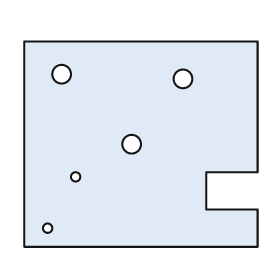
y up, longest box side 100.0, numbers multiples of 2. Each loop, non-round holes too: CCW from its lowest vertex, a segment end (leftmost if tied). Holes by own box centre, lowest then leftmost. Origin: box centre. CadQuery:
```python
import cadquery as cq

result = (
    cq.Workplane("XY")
    .moveTo(-50.0, -44.0)
    .lineTo(50.0, -44.0)
    .lineTo(50.0, -28.0)
    .lineTo(28.0, -28.0)
    .lineTo(28.0, -12.0)
    .lineTo(50.0, -12.0)
    .lineTo(50.0, 44.0)
    .lineTo(-50.0, 44.0)
    .close()
    .moveTo(-40.0, -36.0)
    .circle(2.0)
    .moveTo(-28.0, -14.0)
    .circle(2.0)
    .moveTo(-4.0, 0.0)
    .circle(4.0)
    .moveTo(18.0, 28.0)
    .circle(4.0)
    .moveTo(-34.0, 30.0)
    .circle(4.0)
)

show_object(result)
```